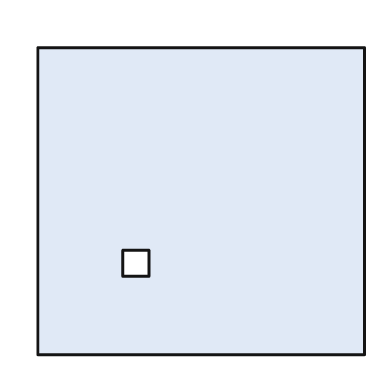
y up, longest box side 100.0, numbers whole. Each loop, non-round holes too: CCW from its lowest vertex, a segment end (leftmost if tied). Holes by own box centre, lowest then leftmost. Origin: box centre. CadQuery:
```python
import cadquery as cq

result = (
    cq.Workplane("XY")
    .moveTo(-50.0, -47.0)
    .lineTo(50.0, -47.0)
    .lineTo(50.0, 47.0)
    .lineTo(-50.0, 47.0)
    .close()
    .moveTo(-24.0, -23.0)
    .lineTo(-16.0, -23.0)
    .lineTo(-16.0, -15.0)
    .lineTo(-24.0, -15.0)
    .close()
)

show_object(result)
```